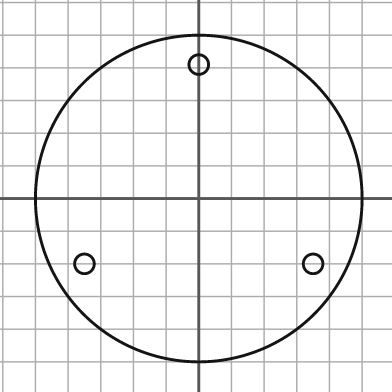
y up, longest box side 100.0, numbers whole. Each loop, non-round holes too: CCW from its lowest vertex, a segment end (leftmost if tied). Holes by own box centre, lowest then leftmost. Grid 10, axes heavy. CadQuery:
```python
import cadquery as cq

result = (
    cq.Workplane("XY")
    .moveTo(0.0, 0.0)
    .circle(50.0)
    .moveTo(-35.0, -20.0)
    .circle(3.0)
    .moveTo(35.0, -20.0)
    .circle(3.0)
    .moveTo(0.0, 41.0)
    .circle(3.0)
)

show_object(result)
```